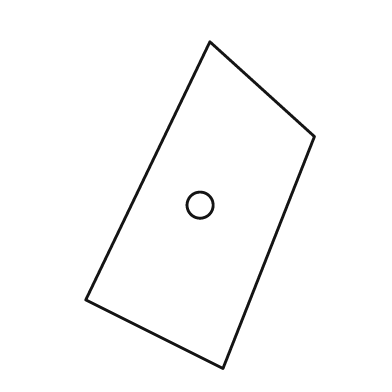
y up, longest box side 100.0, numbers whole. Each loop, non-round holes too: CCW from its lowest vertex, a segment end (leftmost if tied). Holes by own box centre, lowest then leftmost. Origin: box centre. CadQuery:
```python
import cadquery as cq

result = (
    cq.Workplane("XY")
    .moveTo(7.0, -50.0)
    .lineTo(35.0, 21.0)
    .lineTo(3.0, 50.0)
    .lineTo(-35.0, -29.0)
    .close()
    .moveTo(0.0, 0.0)
    .circle(4.0)
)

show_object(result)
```